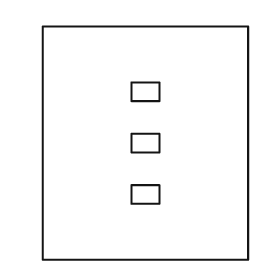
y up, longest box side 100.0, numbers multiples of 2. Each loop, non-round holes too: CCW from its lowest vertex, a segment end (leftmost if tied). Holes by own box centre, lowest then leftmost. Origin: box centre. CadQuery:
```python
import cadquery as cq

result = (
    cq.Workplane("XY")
    .moveTo(-44.0, -50.0)
    .lineTo(44.0, -50.0)
    .lineTo(44.0, 50.0)
    .lineTo(-44.0, 50.0)
    .close()
    .moveTo(-6.0, -26.0)
    .lineTo(6.0, -26.0)
    .lineTo(6.0, -18.0)
    .lineTo(-6.0, -18.0)
    .close()
    .moveTo(-6.0, -4.0)
    .lineTo(6.0, -4.0)
    .lineTo(6.0, 4.0)
    .lineTo(-6.0, 4.0)
    .close()
    .moveTo(-6.0, 18.0)
    .lineTo(6.0, 18.0)
    .lineTo(6.0, 26.0)
    .lineTo(-6.0, 26.0)
    .close()
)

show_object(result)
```